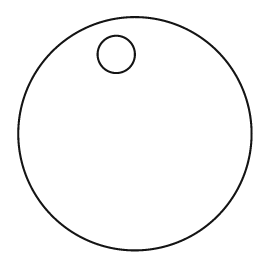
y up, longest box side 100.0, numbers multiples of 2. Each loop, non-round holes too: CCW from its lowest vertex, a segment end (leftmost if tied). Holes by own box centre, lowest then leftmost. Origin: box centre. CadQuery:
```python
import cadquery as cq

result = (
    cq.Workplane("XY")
    .moveTo(0.0, 0.0)
    .circle(50.0)
    .moveTo(-8.0, 34.0)
    .circle(8.0)
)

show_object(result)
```